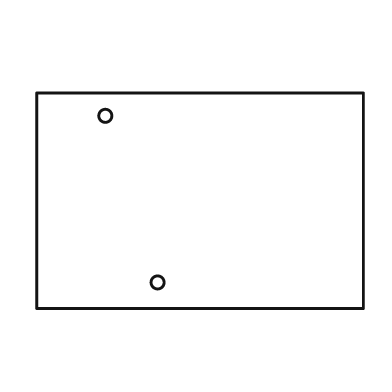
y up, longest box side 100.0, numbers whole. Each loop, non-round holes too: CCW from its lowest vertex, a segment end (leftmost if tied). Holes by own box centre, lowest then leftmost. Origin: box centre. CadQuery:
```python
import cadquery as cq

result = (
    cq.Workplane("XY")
    .moveTo(-50.0, -33.0)
    .lineTo(50.0, -33.0)
    .lineTo(50.0, 33.0)
    .lineTo(-50.0, 33.0)
    .close()
    .moveTo(-13.0, -25.0)
    .circle(2.0)
    .moveTo(-29.0, 26.0)
    .circle(2.0)
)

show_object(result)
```